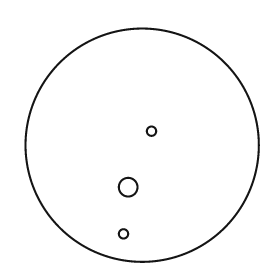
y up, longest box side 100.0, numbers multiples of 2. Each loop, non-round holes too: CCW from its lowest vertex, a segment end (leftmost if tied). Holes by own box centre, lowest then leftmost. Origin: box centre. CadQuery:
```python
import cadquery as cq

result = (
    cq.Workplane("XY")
    .moveTo(0.0, 0.0)
    .circle(50.0)
    .moveTo(-8.0, -38.0)
    .circle(2.0)
    .moveTo(-6.0, -18.0)
    .circle(4.0)
    .moveTo(4.0, 6.0)
    .circle(2.0)
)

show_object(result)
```